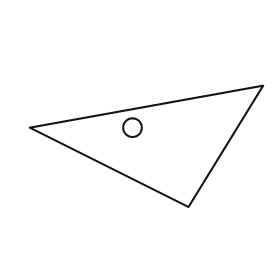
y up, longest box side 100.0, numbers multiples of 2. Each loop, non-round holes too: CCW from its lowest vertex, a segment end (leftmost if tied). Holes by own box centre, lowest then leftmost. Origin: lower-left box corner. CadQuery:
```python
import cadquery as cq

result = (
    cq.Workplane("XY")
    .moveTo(68.0, 0.0)
    .lineTo(100.0, 52.0)
    .lineTo(0.0, 34.0)
    .close()
    .moveTo(44.0, 34.0)
    .circle(4.0)
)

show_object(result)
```